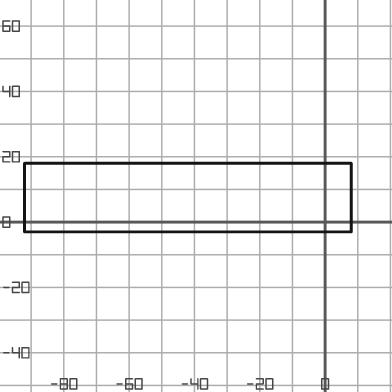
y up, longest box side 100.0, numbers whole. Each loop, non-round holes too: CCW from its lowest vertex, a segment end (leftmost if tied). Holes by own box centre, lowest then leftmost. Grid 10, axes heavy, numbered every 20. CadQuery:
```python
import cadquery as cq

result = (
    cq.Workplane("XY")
    .moveTo(-92.0, -3.0)
    .lineTo(8.0, -3.0)
    .lineTo(8.0, 18.0)
    .lineTo(-92.0, 18.0)
    .close()
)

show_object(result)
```